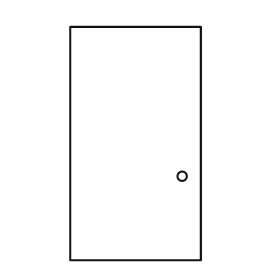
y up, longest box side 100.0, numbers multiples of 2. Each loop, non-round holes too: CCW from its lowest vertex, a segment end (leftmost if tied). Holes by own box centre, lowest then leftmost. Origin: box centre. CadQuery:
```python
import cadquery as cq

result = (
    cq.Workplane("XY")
    .moveTo(-28.0, -50.0)
    .lineTo(28.0, -50.0)
    .lineTo(28.0, 50.0)
    .lineTo(-28.0, 50.0)
    .close()
    .moveTo(20.0, -14.0)
    .circle(2.0)
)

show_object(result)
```